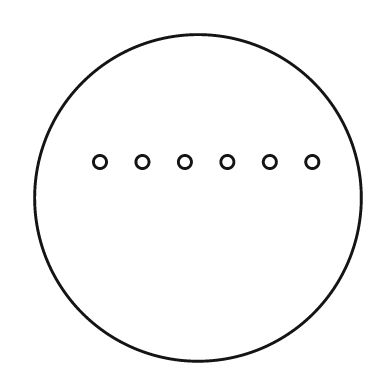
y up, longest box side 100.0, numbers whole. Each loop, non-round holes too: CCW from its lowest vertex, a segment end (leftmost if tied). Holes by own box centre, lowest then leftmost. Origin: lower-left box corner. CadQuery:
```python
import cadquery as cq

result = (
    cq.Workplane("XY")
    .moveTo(50.0, 50.0)
    .circle(50.0)
    .moveTo(20.0, 61.0)
    .circle(2.0)
    .moveTo(33.0, 61.0)
    .circle(2.0)
    .moveTo(46.0, 61.0)
    .circle(2.0)
    .moveTo(59.0, 61.0)
    .circle(2.0)
    .moveTo(72.0, 61.0)
    .circle(2.0)
    .moveTo(85.0, 61.0)
    .circle(2.0)
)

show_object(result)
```